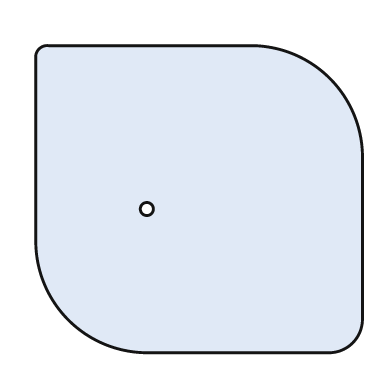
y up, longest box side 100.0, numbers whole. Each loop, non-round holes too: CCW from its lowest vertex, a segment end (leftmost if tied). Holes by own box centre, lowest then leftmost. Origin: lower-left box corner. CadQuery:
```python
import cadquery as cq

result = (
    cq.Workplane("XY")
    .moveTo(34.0, 0.0)
    .lineTo(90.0, 0.0)
    .threePointArc((97.0, 3.0), (100.0, 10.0))
    .lineTo(100.0, 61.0)
    .threePointArc((90.0, 84.0), (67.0, 94.0))
    .lineTo(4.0, 94.0)
    .threePointArc((1.0, 93.0), (0.0, 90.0))
    .lineTo(0.0, 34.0)
    .threePointArc((10.0, 10.0), (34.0, 0.0))
    .close()
    .moveTo(34.0, 44.0)
    .circle(2.0)
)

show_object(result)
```